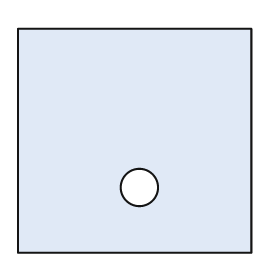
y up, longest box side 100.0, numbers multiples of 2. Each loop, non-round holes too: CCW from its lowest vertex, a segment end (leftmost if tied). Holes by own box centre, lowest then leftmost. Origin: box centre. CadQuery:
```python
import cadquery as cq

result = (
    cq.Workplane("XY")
    .moveTo(-50.0, -48.0)
    .lineTo(50.0, -48.0)
    .lineTo(50.0, 48.0)
    .lineTo(-50.0, 48.0)
    .close()
    .moveTo(2.0, -20.0)
    .circle(8.0)
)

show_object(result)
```